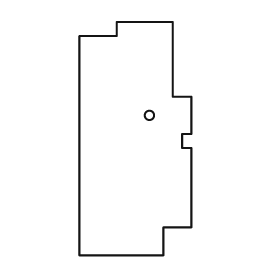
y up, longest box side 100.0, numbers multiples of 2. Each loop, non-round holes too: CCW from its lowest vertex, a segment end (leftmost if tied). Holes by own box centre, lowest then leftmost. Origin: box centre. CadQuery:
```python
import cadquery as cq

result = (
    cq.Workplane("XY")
    .moveTo(-24.0, -50.0)
    .lineTo(12.0, -50.0)
    .lineTo(12.0, -38.0)
    .lineTo(24.0, -38.0)
    .lineTo(24.0, -4.0)
    .lineTo(20.0, -4.0)
    .lineTo(20.0, 2.0)
    .lineTo(24.0, 2.0)
    .lineTo(24.0, 18.0)
    .lineTo(16.0, 18.0)
    .lineTo(16.0, 50.0)
    .lineTo(-8.0, 50.0)
    .lineTo(-8.0, 44.0)
    .lineTo(-24.0, 44.0)
    .close()
    .moveTo(6.0, 10.0)
    .circle(2.0)
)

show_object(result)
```